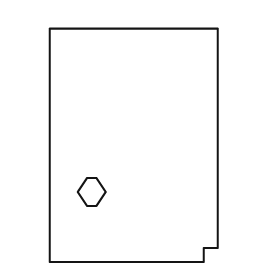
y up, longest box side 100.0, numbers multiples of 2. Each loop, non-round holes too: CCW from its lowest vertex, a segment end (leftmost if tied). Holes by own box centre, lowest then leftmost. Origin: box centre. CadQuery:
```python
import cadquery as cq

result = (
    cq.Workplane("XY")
    .moveTo(-36.0, -50.0)
    .lineTo(30.0, -50.0)
    .lineTo(30.0, -44.0)
    .lineTo(36.0, -44.0)
    .lineTo(36.0, 50.0)
    .lineTo(-36.0, 50.0)
    .close()
    .moveTo(-20.0, -26.0)
    .lineTo(-16.0, -26.0)
    .lineTo(-12.0, -20.0)
    .lineTo(-16.0, -14.0)
    .lineTo(-20.0, -14.0)
    .lineTo(-24.0, -20.0)
    .close()
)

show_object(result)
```